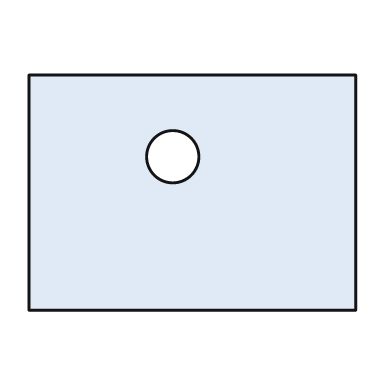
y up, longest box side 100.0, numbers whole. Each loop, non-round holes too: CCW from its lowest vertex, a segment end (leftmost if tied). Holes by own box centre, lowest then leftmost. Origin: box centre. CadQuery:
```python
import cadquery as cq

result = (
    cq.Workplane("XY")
    .moveTo(-50.0, -36.0)
    .lineTo(50.0, -36.0)
    .lineTo(50.0, 36.0)
    .lineTo(-50.0, 36.0)
    .close()
    .moveTo(-6.0, 11.0)
    .circle(8.0)
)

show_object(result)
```